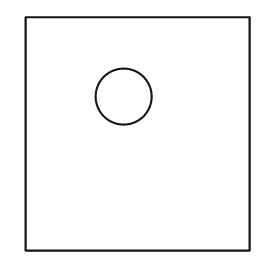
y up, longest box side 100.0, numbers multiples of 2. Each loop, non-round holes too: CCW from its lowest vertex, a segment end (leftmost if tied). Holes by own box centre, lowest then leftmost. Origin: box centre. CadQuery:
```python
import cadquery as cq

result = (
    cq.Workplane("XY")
    .moveTo(-48.0, -50.0)
    .lineTo(48.0, -50.0)
    .lineTo(48.0, 50.0)
    .lineTo(-48.0, 50.0)
    .close()
    .moveTo(-6.0, 16.0)
    .circle(12.0)
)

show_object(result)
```